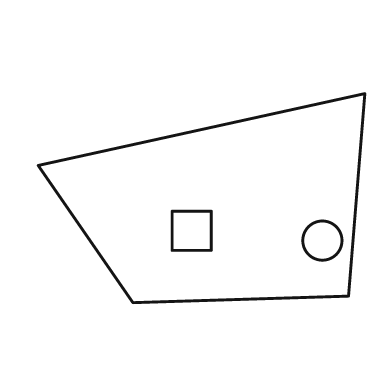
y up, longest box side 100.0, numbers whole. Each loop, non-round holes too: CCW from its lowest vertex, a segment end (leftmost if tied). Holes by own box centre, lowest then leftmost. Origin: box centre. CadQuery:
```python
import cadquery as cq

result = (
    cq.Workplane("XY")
    .moveTo(-21.0, -32.0)
    .lineTo(45.0, -30.0)
    .lineTo(50.0, 32.0)
    .lineTo(-50.0, 10.0)
    .close()
    .moveTo(37.0, -13.0)
    .circle(6.0)
    .moveTo(-9.0, -16.0)
    .lineTo(3.0, -16.0)
    .lineTo(3.0, -4.0)
    .lineTo(-9.0, -4.0)
    .close()
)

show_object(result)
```